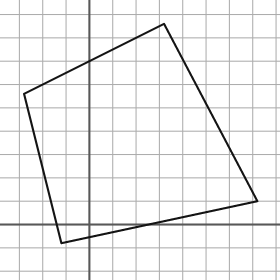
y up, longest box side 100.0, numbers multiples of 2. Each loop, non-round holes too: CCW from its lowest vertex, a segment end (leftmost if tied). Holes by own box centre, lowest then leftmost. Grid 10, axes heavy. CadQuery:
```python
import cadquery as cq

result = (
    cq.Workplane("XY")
    .moveTo(-12.0, -8.0)
    .lineTo(72.0, 10.0)
    .lineTo(32.0, 86.0)
    .lineTo(-28.0, 56.0)
    .close()
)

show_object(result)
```